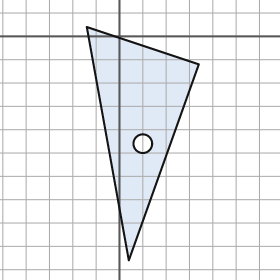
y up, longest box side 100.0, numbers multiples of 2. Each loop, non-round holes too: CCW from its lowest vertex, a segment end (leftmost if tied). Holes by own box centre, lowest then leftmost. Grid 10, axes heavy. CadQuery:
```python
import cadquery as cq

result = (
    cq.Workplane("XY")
    .moveTo(4.0, -96.0)
    .lineTo(34.0, -12.0)
    .lineTo(-14.0, 4.0)
    .close()
    .moveTo(10.0, -46.0)
    .circle(4.0)
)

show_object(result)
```